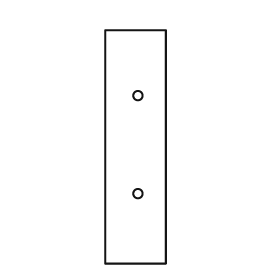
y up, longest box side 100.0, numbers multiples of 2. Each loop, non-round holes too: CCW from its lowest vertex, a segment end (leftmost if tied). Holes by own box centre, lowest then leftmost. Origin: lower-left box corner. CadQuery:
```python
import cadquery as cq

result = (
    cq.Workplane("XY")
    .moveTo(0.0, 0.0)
    .lineTo(26.0, 0.0)
    .lineTo(26.0, 100.0)
    .lineTo(0.0, 100.0)
    .close()
    .moveTo(14.0, 30.0)
    .circle(2.0)
    .moveTo(14.0, 72.0)
    .circle(2.0)
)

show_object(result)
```